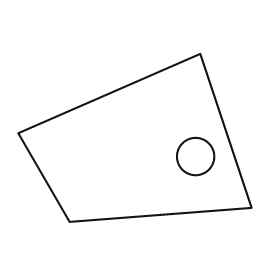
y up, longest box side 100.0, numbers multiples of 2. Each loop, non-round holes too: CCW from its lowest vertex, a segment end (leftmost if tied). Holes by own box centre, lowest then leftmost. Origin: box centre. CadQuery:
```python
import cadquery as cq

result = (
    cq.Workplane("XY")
    .moveTo(-28.0, -36.0)
    .lineTo(50.0, -30.0)
    .lineTo(28.0, 36.0)
    .lineTo(-50.0, 2.0)
    .close()
    .moveTo(26.0, -8.0)
    .circle(8.0)
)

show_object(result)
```